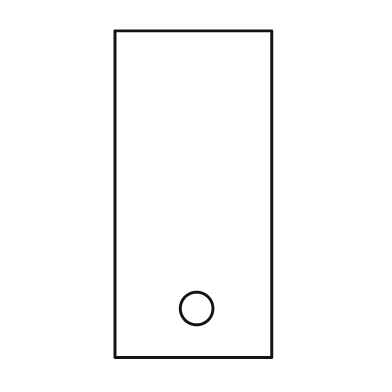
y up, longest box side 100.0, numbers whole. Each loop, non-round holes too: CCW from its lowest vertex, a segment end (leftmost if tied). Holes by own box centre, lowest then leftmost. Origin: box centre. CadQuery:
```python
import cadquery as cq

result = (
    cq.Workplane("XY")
    .moveTo(-24.0, -50.0)
    .lineTo(24.0, -50.0)
    .lineTo(24.0, 50.0)
    .lineTo(-24.0, 50.0)
    .close()
    .moveTo(1.0, -35.0)
    .circle(5.0)
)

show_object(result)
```